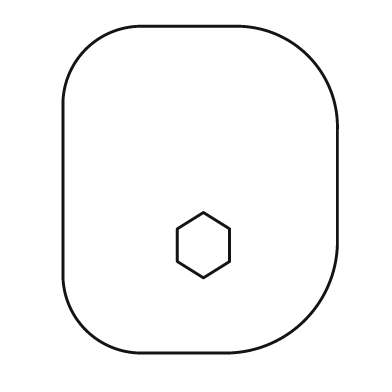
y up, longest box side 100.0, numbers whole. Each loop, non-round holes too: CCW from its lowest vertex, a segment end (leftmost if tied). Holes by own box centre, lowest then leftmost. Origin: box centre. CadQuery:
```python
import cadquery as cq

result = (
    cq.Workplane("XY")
    .moveTo(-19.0, -50.0)
    .lineTo(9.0, -50.0)
    .threePointArc((32.0, -40.0), (42.0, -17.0))
    .lineTo(42.0, 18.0)
    .threePointArc((33.0, 41.0), (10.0, 50.0))
    .lineTo(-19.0, 50.0)
    .threePointArc((-35.0, 43.0), (-42.0, 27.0))
    .lineTo(-42.0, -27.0)
    .threePointArc((-35.0, -43.0), (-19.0, -50.0))
    .close()
    .moveTo(1.0, -27.0)
    .lineTo(9.0, -22.0)
    .lineTo(9.0, -12.0)
    .lineTo(1.0, -7.0)
    .lineTo(-7.0, -12.0)
    .lineTo(-7.0, -22.0)
    .close()
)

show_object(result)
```